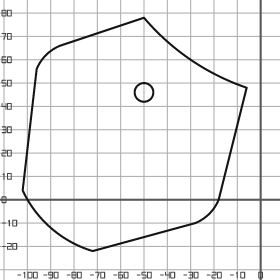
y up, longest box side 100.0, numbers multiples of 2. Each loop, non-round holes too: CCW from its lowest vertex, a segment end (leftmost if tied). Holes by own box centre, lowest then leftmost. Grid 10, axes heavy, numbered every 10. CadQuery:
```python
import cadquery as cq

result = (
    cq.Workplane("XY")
    .moveTo(-72.0, -22.0)
    .lineTo(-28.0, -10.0)
    .threePointArc((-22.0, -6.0), (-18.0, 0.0))
    .lineTo(-6.0, 48.0)
    .threePointArc((-30.0, 60.0), (-50.0, 78.0))
    .lineTo(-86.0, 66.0)
    .threePointArc((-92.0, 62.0), (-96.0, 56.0))
    .lineTo(-102.0, 4.0)
    .threePointArc((-90.0, -12.0), (-72.0, -22.0))
    .close()
    .moveTo(-50.0, 46.0)
    .circle(4.0)
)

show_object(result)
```